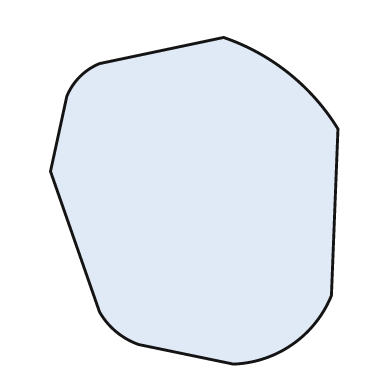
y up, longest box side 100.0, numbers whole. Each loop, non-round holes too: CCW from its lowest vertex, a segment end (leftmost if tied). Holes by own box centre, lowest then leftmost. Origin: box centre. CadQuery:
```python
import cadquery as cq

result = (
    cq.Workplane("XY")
    .moveTo(12.0, -50.0)
    .threePointArc((30.0, -44.0), (42.0, -29.0))
    .lineTo(44.0, 22.0)
    .threePointArc((29.0, 39.0), (9.0, 50.0))
    .lineTo(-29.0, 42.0)
    .threePointArc((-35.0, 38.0), (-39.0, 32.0))
    .lineTo(-44.0, 9.0)
    .lineTo(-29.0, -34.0)
    .threePointArc((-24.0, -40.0), (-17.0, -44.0))
    .close()
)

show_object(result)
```